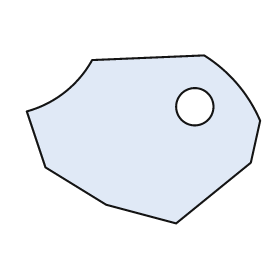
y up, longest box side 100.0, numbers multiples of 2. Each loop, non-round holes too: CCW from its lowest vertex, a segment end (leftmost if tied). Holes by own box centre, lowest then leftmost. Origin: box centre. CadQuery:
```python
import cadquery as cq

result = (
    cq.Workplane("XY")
    .moveTo(14.0, -36.0)
    .lineTo(46.0, -10.0)
    .lineTo(50.0, 8.0)
    .threePointArc((40.0, 24.0), (26.0, 36.0))
    .lineTo(-22.0, 34.0)
    .threePointArc((-34.0, 20.0), (-50.0, 12.0))
    .lineTo(-42.0, -12.0)
    .lineTo(-16.0, -28.0)
    .close()
    .moveTo(22.0, 14.0)
    .circle(8.0)
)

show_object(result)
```